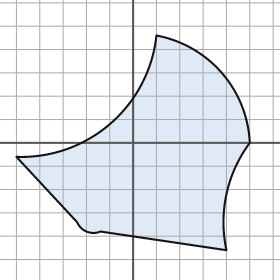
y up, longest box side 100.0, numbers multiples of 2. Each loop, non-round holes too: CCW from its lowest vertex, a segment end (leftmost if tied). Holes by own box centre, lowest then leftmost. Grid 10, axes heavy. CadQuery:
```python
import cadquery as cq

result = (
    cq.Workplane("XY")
    .moveTo(40.0, -46.0)
    .threePointArc((40.0, -22.0), (50.0, 0.0))
    .threePointArc((38.0, 30.0), (10.0, 46.0))
    .threePointArc((-10.0, 8.0), (-50.0, -6.0))
    .lineTo(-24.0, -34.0)
    .threePointArc((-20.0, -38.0), (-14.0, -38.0))
    .close()
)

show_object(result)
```